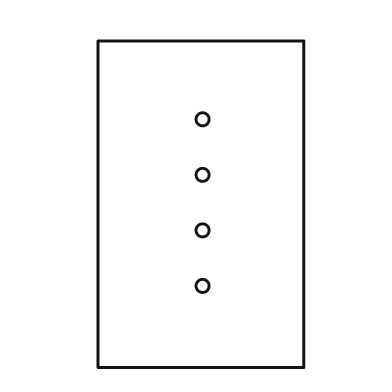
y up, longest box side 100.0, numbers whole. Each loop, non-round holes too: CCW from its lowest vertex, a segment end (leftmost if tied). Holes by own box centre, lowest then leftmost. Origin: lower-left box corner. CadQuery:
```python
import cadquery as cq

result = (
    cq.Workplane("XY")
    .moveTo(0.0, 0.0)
    .lineTo(63.0, 0.0)
    .lineTo(63.0, 100.0)
    .lineTo(0.0, 100.0)
    .close()
    .moveTo(32.0, 25.0)
    .circle(2.0)
    .moveTo(32.0, 42.0)
    .circle(2.0)
    .moveTo(32.0, 59.0)
    .circle(2.0)
    .moveTo(32.0, 76.0)
    .circle(2.0)
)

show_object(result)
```